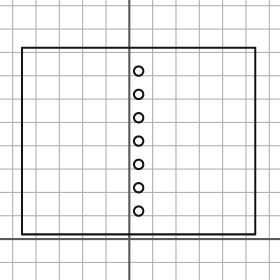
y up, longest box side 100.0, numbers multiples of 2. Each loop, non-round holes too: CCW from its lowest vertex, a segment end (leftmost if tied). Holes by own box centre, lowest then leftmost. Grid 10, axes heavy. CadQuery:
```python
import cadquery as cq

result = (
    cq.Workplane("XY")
    .moveTo(-46.0, 2.0)
    .lineTo(54.0, 2.0)
    .lineTo(54.0, 82.0)
    .lineTo(-46.0, 82.0)
    .close()
    .moveTo(4.0, 12.0)
    .circle(2.0)
    .moveTo(4.0, 22.0)
    .circle(2.0)
    .moveTo(4.0, 32.0)
    .circle(2.0)
    .moveTo(4.0, 42.0)
    .circle(2.0)
    .moveTo(4.0, 52.0)
    .circle(2.0)
    .moveTo(4.0, 62.0)
    .circle(2.0)
    .moveTo(4.0, 72.0)
    .circle(2.0)
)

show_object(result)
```